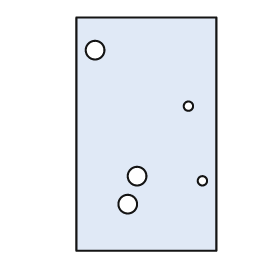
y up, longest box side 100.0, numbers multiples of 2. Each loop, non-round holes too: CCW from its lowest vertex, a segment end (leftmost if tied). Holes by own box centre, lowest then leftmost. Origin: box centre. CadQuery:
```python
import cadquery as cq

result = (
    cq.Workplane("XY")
    .moveTo(-30.0, -50.0)
    .lineTo(30.0, -50.0)
    .lineTo(30.0, 50.0)
    .lineTo(-30.0, 50.0)
    .close()
    .moveTo(-8.0, -30.0)
    .circle(4.0)
    .moveTo(24.0, -20.0)
    .circle(2.0)
    .moveTo(-4.0, -18.0)
    .circle(4.0)
    .moveTo(18.0, 12.0)
    .circle(2.0)
    .moveTo(-22.0, 36.0)
    .circle(4.0)
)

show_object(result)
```